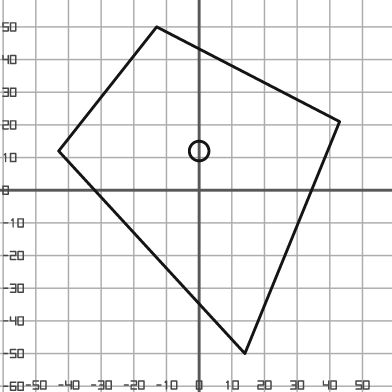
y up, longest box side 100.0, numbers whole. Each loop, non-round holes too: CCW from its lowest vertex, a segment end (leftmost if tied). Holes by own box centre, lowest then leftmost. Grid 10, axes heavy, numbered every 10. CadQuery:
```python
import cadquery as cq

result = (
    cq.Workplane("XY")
    .moveTo(14.0, -50.0)
    .lineTo(43.0, 21.0)
    .lineTo(-13.0, 50.0)
    .lineTo(-43.0, 12.0)
    .close()
    .moveTo(0.0, 12.0)
    .circle(3.0)
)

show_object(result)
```